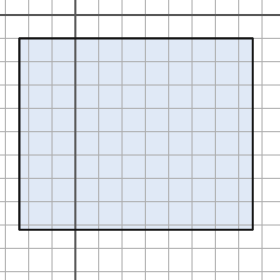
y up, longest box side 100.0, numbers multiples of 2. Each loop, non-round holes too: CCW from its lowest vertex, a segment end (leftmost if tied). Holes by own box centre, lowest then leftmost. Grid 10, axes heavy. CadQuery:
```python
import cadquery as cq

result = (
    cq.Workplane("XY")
    .moveTo(-24.0, -92.0)
    .lineTo(76.0, -92.0)
    .lineTo(76.0, -10.0)
    .lineTo(-24.0, -10.0)
    .close()
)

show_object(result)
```